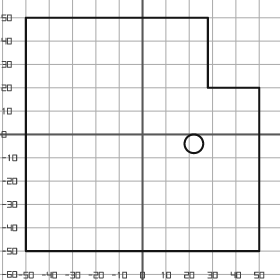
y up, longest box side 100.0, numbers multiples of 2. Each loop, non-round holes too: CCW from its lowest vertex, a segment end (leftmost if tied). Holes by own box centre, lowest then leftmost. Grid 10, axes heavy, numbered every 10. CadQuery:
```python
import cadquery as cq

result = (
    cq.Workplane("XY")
    .moveTo(-50.0, -50.0)
    .lineTo(50.0, -50.0)
    .lineTo(50.0, 20.0)
    .lineTo(28.0, 20.0)
    .lineTo(28.0, 50.0)
    .lineTo(-50.0, 50.0)
    .close()
    .moveTo(22.0, -4.0)
    .circle(4.0)
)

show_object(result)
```